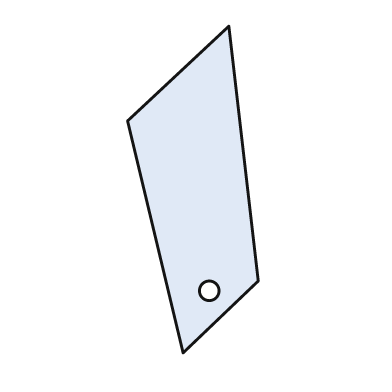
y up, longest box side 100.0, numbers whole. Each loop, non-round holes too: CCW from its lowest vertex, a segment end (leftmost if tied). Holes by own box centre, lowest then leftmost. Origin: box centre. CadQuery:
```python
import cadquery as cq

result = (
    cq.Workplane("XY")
    .moveTo(-3.0, -50.0)
    .lineTo(20.0, -28.0)
    .lineTo(11.0, 50.0)
    .lineTo(-20.0, 21.0)
    .close()
    .moveTo(5.0, -31.0)
    .circle(3.0)
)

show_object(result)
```